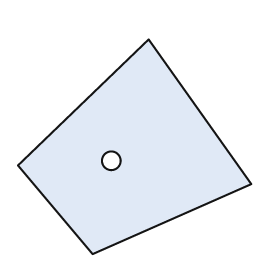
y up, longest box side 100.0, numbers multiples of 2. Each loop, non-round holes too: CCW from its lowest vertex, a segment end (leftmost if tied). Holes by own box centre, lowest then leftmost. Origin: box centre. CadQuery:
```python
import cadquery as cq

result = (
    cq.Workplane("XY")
    .moveTo(-18.0, -46.0)
    .lineTo(50.0, -16.0)
    .lineTo(6.0, 46.0)
    .lineTo(-50.0, -8.0)
    .close()
    .moveTo(-10.0, -6.0)
    .circle(4.0)
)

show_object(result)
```